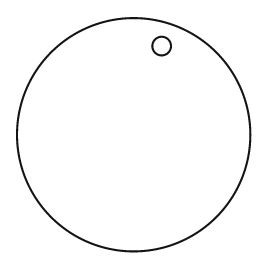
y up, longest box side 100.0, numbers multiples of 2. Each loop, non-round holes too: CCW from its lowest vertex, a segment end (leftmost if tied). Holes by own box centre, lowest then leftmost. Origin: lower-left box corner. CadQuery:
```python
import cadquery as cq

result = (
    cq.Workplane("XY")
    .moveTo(50.0, 50.0)
    .circle(50.0)
    .moveTo(62.0, 88.0)
    .circle(4.0)
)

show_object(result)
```